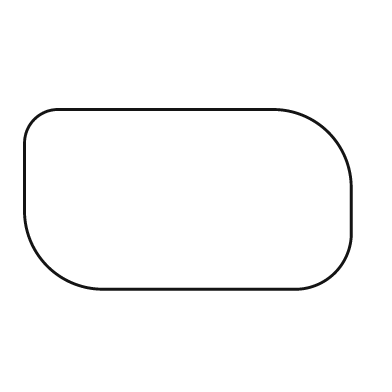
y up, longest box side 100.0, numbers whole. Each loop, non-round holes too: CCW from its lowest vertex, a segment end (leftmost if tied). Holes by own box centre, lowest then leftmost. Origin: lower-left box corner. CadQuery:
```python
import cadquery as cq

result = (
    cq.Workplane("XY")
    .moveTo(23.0, 0.0)
    .lineTo(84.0, 0.0)
    .threePointArc((95.0, 5.0), (100.0, 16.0))
    .lineTo(100.0, 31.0)
    .threePointArc((93.0, 48.0), (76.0, 55.0))
    .lineTo(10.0, 55.0)
    .threePointArc((3.0, 52.0), (0.0, 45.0))
    .lineTo(0.0, 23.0)
    .threePointArc((7.0, 7.0), (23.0, 0.0))
    .close()
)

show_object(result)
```